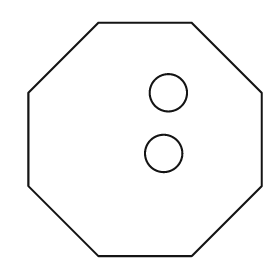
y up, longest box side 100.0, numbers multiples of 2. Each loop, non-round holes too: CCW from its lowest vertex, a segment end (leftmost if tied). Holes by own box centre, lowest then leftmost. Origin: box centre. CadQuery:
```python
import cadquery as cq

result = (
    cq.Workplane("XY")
    .moveTo(-20.0, -50.0)
    .lineTo(20.0, -50.0)
    .lineTo(50.0, -20.0)
    .lineTo(50.0, 20.0)
    .lineTo(20.0, 50.0)
    .lineTo(-20.0, 50.0)
    .lineTo(-50.0, 20.0)
    .lineTo(-50.0, -20.0)
    .close()
    .moveTo(8.0, -6.0)
    .circle(8.0)
    .moveTo(10.0, 20.0)
    .circle(8.0)
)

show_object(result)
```